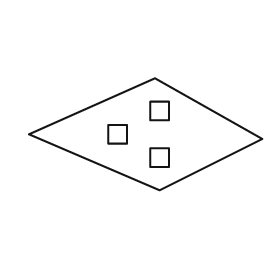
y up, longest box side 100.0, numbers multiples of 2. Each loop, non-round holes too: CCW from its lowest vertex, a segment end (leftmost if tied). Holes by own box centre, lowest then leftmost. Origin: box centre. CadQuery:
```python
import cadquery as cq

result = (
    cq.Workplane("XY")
    .moveTo(6.0, -24.0)
    .lineTo(50.0, -2.0)
    .lineTo(4.0, 24.0)
    .lineTo(-50.0, 0.0)
    .close()
    .moveTo(2.0, -14.0)
    .lineTo(10.0, -14.0)
    .lineTo(10.0, -6.0)
    .lineTo(2.0, -6.0)
    .close()
    .moveTo(-16.0, -4.0)
    .lineTo(-8.0, -4.0)
    .lineTo(-8.0, 4.0)
    .lineTo(-16.0, 4.0)
    .close()
    .moveTo(2.0, 6.0)
    .lineTo(10.0, 6.0)
    .lineTo(10.0, 14.0)
    .lineTo(2.0, 14.0)
    .close()
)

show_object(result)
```